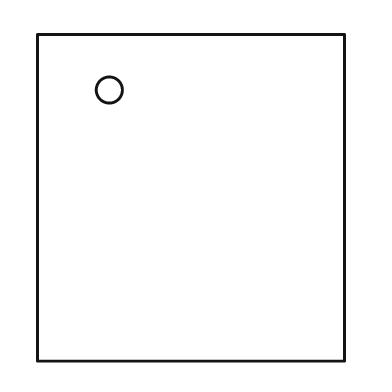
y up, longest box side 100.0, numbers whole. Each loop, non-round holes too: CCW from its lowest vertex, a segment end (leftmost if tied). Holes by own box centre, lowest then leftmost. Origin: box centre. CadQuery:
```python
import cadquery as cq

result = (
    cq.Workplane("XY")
    .moveTo(-47.0, -50.0)
    .lineTo(47.0, -50.0)
    .lineTo(47.0, 50.0)
    .lineTo(-47.0, 50.0)
    .close()
    .moveTo(-25.0, 33.0)
    .circle(4.0)
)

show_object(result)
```